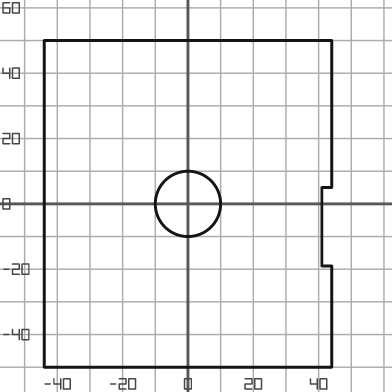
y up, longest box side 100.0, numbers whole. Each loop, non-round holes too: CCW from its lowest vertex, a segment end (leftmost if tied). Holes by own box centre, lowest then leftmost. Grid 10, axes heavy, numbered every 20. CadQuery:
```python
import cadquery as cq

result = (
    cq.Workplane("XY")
    .moveTo(-44.0, -50.0)
    .lineTo(44.0, -50.0)
    .lineTo(44.0, -19.0)
    .lineTo(41.0, -19.0)
    .lineTo(41.0, 5.0)
    .lineTo(44.0, 5.0)
    .lineTo(44.0, 50.0)
    .lineTo(-44.0, 50.0)
    .close()
    .moveTo(0.0, 0.0)
    .circle(10.0)
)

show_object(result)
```